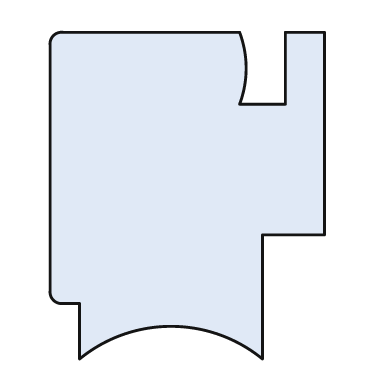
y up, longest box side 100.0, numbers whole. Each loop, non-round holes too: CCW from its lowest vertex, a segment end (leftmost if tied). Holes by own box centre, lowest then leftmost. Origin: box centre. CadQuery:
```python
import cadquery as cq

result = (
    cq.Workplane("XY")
    .moveTo(-33.0, -50.0)
    .threePointArc((-5.0, -40.0), (23.0, -50.0))
    .lineTo(23.0, -12.0)
    .lineTo(42.0, -12.0)
    .lineTo(42.0, 50.0)
    .lineTo(30.0, 50.0)
    .lineTo(30.0, 28.0)
    .lineTo(16.0, 28.0)
    .threePointArc((18.0, 39.0), (16.0, 50.0))
    .lineTo(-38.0, 50.0)
    .threePointArc((-41.0, 49.0), (-42.0, 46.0))
    .lineTo(-42.0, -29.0)
    .threePointArc((-41.0, -32.0), (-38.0, -33.0))
    .lineTo(-33.0, -33.0)
    .close()
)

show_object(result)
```